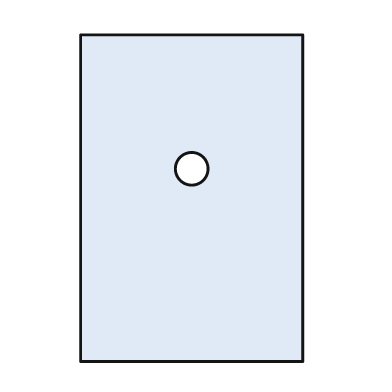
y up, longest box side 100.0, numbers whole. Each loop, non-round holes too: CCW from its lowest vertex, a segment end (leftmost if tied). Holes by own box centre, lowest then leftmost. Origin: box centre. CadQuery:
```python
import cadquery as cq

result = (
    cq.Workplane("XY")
    .moveTo(-34.0, -50.0)
    .lineTo(34.0, -50.0)
    .lineTo(34.0, 50.0)
    .lineTo(-34.0, 50.0)
    .close()
    .moveTo(0.0, 9.0)
    .circle(5.0)
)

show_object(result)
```